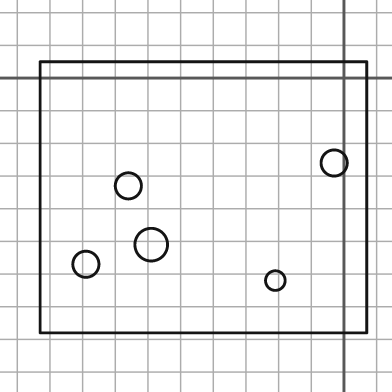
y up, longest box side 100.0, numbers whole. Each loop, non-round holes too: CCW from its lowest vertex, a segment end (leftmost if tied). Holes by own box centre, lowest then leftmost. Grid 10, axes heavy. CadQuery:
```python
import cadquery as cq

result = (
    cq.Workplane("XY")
    .moveTo(-93.0, -78.0)
    .lineTo(7.0, -78.0)
    .lineTo(7.0, 5.0)
    .lineTo(-93.0, 5.0)
    .close()
    .moveTo(-21.0, -62.0)
    .circle(3.0)
    .moveTo(-79.0, -57.0)
    .circle(4.0)
    .moveTo(-59.0, -51.0)
    .circle(5.0)
    .moveTo(-66.0, -33.0)
    .circle(4.0)
    .moveTo(-3.0, -26.0)
    .circle(4.0)
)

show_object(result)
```